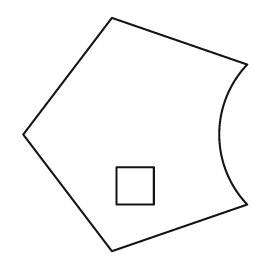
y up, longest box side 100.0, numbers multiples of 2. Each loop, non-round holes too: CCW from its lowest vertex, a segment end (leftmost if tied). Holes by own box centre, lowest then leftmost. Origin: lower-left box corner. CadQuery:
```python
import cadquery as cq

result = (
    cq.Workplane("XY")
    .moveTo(38.0, 0.0)
    .lineTo(96.0, 20.0)
    .threePointArc((84.0, 50.0), (96.0, 80.0))
    .lineTo(38.0, 100.0)
    .lineTo(0.0, 50.0)
    .close()
    .moveTo(40.0, 20.0)
    .lineTo(56.0, 20.0)
    .lineTo(56.0, 36.0)
    .lineTo(40.0, 36.0)
    .close()
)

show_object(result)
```